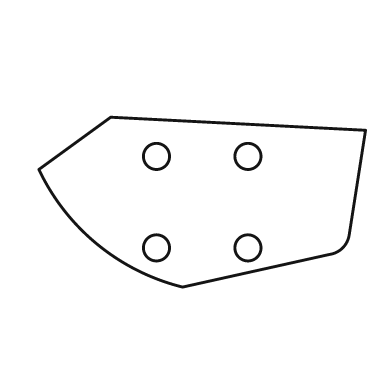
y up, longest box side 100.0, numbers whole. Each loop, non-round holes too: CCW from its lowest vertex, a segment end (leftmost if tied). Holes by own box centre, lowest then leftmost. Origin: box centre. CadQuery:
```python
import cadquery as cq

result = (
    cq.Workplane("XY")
    .moveTo(-6.0, -26.0)
    .lineTo(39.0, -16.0)
    .threePointArc((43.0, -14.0), (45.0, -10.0))
    .lineTo(50.0, 22.0)
    .lineTo(-28.0, 26.0)
    .lineTo(-50.0, 10.0)
    .threePointArc((-32.0, -13.0), (-6.0, -26.0))
    .close()
    .moveTo(-14.0, -14.0)
    .circle(4.0)
    .moveTo(14.0, -14.0)
    .circle(4.0)
    .moveTo(-14.0, 14.0)
    .circle(4.0)
    .moveTo(14.0, 14.0)
    .circle(4.0)
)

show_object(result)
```